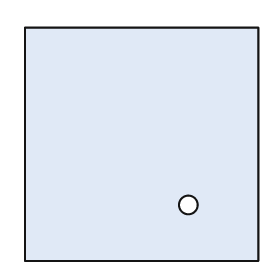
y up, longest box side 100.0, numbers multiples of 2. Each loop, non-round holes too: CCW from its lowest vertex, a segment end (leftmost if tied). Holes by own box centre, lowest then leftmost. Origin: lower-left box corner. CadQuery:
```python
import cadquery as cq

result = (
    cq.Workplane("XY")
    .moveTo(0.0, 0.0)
    .lineTo(100.0, 0.0)
    .lineTo(100.0, 100.0)
    .lineTo(0.0, 100.0)
    .close()
    .moveTo(70.0, 24.0)
    .circle(4.0)
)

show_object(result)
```